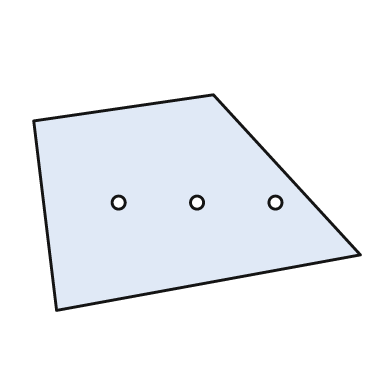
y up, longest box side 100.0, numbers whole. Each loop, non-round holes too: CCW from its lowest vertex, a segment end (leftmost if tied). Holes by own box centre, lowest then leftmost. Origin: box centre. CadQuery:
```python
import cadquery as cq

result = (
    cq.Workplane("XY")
    .moveTo(-43.0, -33.0)
    .lineTo(50.0, -16.0)
    .lineTo(5.0, 33.0)
    .lineTo(-50.0, 25.0)
    .close()
    .moveTo(-24.0, 0.0)
    .circle(2.0)
    .moveTo(0.0, 0.0)
    .circle(2.0)
    .moveTo(24.0, 0.0)
    .circle(2.0)
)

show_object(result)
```